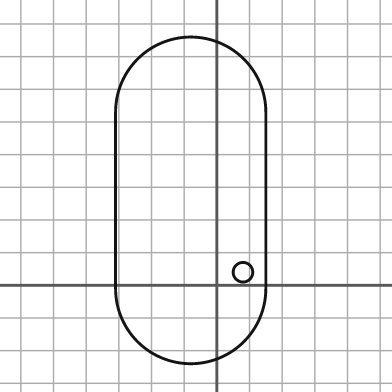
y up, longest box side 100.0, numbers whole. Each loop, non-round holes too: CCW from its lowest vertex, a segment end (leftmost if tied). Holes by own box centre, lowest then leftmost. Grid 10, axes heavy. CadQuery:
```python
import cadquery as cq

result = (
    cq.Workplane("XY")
    .moveTo(-31.0, -1.0)
    .threePointArc((-8.0, -24.0), (15.0, -1.0))
    .lineTo(15.0, 53.0)
    .threePointArc((-8.0, 76.0), (-31.0, 53.0))
    .close()
    .moveTo(8.0, 4.0)
    .circle(3.0)
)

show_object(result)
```